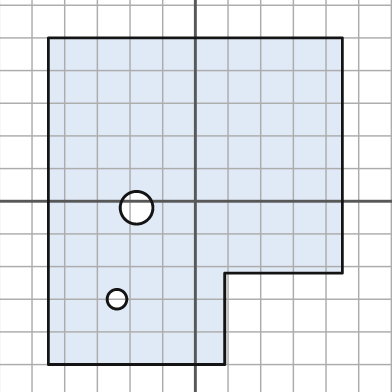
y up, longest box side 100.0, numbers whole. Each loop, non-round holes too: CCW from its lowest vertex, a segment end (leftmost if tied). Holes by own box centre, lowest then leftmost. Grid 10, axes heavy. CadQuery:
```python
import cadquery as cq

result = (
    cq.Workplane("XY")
    .moveTo(-45.0, -50.0)
    .lineTo(9.0, -50.0)
    .lineTo(9.0, -22.0)
    .lineTo(45.0, -22.0)
    .lineTo(45.0, 50.0)
    .lineTo(-45.0, 50.0)
    .close()
    .moveTo(-24.0, -30.0)
    .circle(3.0)
    .moveTo(-18.0, -2.0)
    .circle(5.0)
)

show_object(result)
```